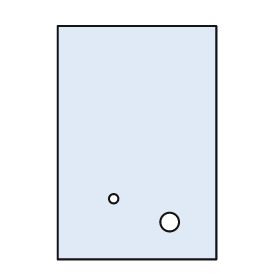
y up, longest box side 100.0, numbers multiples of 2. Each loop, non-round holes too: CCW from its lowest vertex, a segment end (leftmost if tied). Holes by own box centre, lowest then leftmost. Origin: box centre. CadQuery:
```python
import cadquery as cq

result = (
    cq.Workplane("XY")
    .moveTo(-34.0, -50.0)
    .lineTo(34.0, -50.0)
    .lineTo(34.0, 50.0)
    .lineTo(-34.0, 50.0)
    .close()
    .moveTo(14.0, -34.0)
    .circle(4.0)
    .moveTo(-10.0, -24.0)
    .circle(2.0)
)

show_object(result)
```